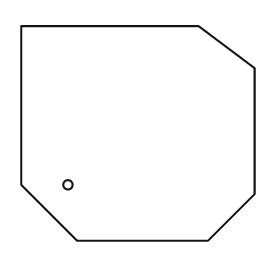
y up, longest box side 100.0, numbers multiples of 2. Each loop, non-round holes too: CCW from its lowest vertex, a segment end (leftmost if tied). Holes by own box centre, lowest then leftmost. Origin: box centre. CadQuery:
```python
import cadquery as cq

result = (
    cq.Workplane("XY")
    .moveTo(-26.0, -46.0)
    .lineTo(30.0, -46.0)
    .lineTo(50.0, -26.0)
    .lineTo(50.0, 28.0)
    .lineTo(26.0, 46.0)
    .lineTo(-50.0, 46.0)
    .lineTo(-50.0, -22.0)
    .close()
    .moveTo(-30.0, -22.0)
    .circle(2.0)
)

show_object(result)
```